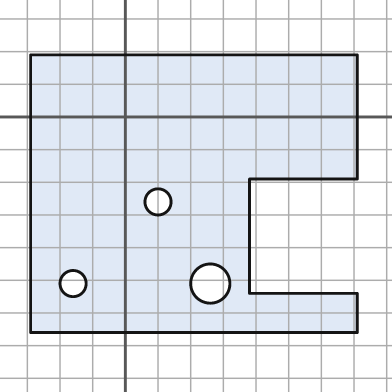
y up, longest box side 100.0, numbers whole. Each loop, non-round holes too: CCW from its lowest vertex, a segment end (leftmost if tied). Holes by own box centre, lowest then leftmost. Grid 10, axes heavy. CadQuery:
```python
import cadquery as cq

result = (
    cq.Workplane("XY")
    .moveTo(-29.0, -66.0)
    .lineTo(71.0, -66.0)
    .lineTo(71.0, -54.0)
    .lineTo(38.0, -54.0)
    .lineTo(38.0, -19.0)
    .lineTo(71.0, -19.0)
    .lineTo(71.0, 19.0)
    .lineTo(-29.0, 19.0)
    .close()
    .moveTo(-16.0, -51.0)
    .circle(4.0)
    .moveTo(26.0, -51.0)
    .circle(6.0)
    .moveTo(10.0, -26.0)
    .circle(4.0)
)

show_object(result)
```